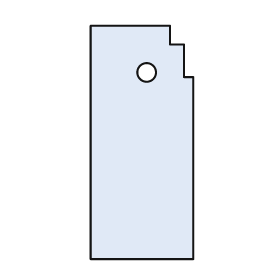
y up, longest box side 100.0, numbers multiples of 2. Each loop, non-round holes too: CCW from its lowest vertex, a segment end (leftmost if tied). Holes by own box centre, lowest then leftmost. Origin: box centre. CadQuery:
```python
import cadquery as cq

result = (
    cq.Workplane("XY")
    .moveTo(-22.0, -50.0)
    .lineTo(22.0, -50.0)
    .lineTo(22.0, 28.0)
    .lineTo(18.0, 28.0)
    .lineTo(18.0, 42.0)
    .lineTo(12.0, 42.0)
    .lineTo(12.0, 50.0)
    .lineTo(-22.0, 50.0)
    .close()
    .moveTo(2.0, 30.0)
    .circle(4.0)
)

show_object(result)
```